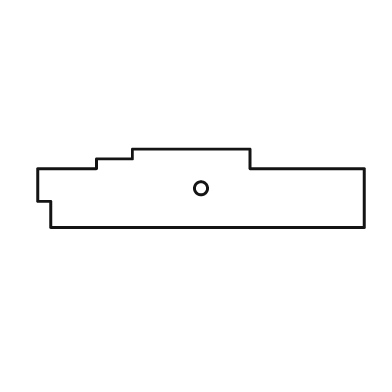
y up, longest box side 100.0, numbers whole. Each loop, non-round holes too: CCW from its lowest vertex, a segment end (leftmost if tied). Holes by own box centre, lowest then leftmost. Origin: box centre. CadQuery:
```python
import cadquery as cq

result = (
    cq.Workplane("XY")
    .moveTo(-46.0, -12.0)
    .lineTo(50.0, -12.0)
    .lineTo(50.0, 6.0)
    .lineTo(15.0, 6.0)
    .lineTo(15.0, 12.0)
    .lineTo(-21.0, 12.0)
    .lineTo(-21.0, 9.0)
    .lineTo(-32.0, 9.0)
    .lineTo(-32.0, 6.0)
    .lineTo(-50.0, 6.0)
    .lineTo(-50.0, -4.0)
    .lineTo(-46.0, -4.0)
    .close()
    .moveTo(0.0, 0.0)
    .circle(2.0)
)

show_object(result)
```